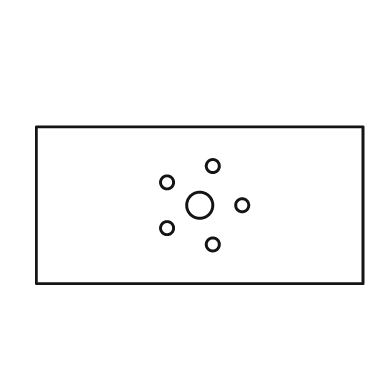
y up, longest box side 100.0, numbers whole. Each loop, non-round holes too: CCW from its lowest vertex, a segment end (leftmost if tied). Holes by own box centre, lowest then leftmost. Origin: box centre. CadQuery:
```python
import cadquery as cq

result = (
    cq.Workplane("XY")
    .moveTo(-50.0, -24.0)
    .lineTo(50.0, -24.0)
    .lineTo(50.0, 24.0)
    .lineTo(-50.0, 24.0)
    .close()
    .moveTo(4.0, -12.0)
    .circle(2.0)
    .moveTo(-10.0, -7.0)
    .circle(2.0)
    .moveTo(0.0, 0.0)
    .circle(4.0)
    .moveTo(13.0, 0.0)
    .circle(2.0)
    .moveTo(-10.0, 7.0)
    .circle(2.0)
    .moveTo(4.0, 12.0)
    .circle(2.0)
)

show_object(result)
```